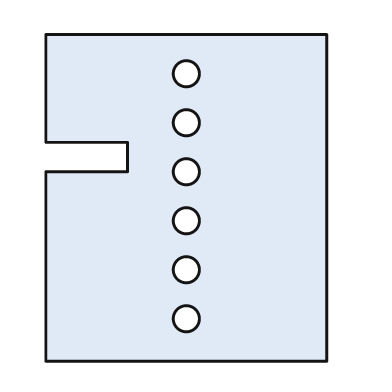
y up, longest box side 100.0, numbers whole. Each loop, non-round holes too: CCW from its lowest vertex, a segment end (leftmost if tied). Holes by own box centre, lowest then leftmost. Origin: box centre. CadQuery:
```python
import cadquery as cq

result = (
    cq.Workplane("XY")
    .moveTo(-43.0, -50.0)
    .lineTo(43.0, -50.0)
    .lineTo(43.0, 50.0)
    .lineTo(-43.0, 50.0)
    .lineTo(-43.0, 17.0)
    .lineTo(-18.0, 17.0)
    .lineTo(-18.0, 8.0)
    .lineTo(-43.0, 8.0)
    .close()
    .moveTo(0.0, -37.0)
    .circle(4.0)
    .moveTo(0.0, -22.0)
    .circle(4.0)
    .moveTo(0.0, -7.0)
    .circle(4.0)
    .moveTo(0.0, 8.0)
    .circle(4.0)
    .moveTo(0.0, 23.0)
    .circle(4.0)
    .moveTo(0.0, 38.0)
    .circle(4.0)
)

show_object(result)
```